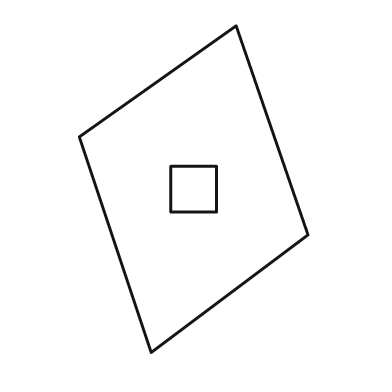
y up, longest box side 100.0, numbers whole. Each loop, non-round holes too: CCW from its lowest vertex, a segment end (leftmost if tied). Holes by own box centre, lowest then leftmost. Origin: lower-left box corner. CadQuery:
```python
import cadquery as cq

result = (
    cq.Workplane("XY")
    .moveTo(22.0, 0.0)
    .lineTo(70.0, 36.0)
    .lineTo(48.0, 100.0)
    .lineTo(0.0, 66.0)
    .close()
    .moveTo(28.0, 43.0)
    .lineTo(42.0, 43.0)
    .lineTo(42.0, 57.0)
    .lineTo(28.0, 57.0)
    .close()
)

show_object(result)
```